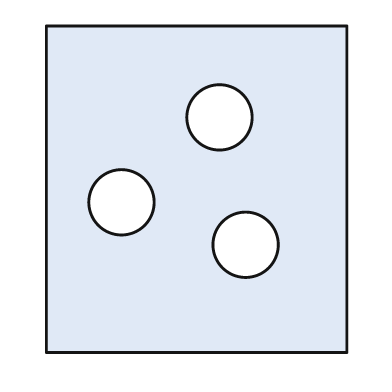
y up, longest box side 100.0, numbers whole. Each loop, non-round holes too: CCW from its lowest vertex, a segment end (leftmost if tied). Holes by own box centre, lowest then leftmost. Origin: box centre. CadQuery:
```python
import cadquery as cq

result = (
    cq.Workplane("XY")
    .moveTo(-46.0, -50.0)
    .lineTo(46.0, -50.0)
    .lineTo(46.0, 50.0)
    .lineTo(-46.0, 50.0)
    .close()
    .moveTo(15.0, -17.0)
    .circle(10.0)
    .moveTo(-23.0, -4.0)
    .circle(10.0)
    .moveTo(7.0, 22.0)
    .circle(10.0)
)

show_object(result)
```